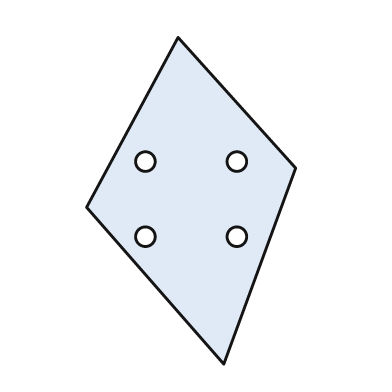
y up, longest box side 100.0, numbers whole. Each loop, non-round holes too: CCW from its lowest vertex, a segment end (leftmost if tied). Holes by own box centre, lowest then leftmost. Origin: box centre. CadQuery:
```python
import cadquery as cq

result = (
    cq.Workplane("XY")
    .moveTo(10.0, -50.0)
    .lineTo(32.0, 10.0)
    .lineTo(-4.0, 50.0)
    .lineTo(-32.0, -2.0)
    .close()
    .moveTo(-14.0, -11.0)
    .circle(3.0)
    .moveTo(14.0, -11.0)
    .circle(3.0)
    .moveTo(-14.0, 12.0)
    .circle(3.0)
    .moveTo(14.0, 12.0)
    .circle(3.0)
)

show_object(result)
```